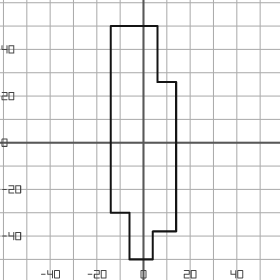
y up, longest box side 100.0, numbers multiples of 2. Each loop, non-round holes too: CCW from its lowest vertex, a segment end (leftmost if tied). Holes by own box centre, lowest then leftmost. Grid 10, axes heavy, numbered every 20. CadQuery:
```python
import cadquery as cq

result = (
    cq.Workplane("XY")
    .moveTo(-6.0, -50.0)
    .lineTo(4.0, -50.0)
    .lineTo(4.0, -38.0)
    .lineTo(14.0, -38.0)
    .lineTo(14.0, 26.0)
    .lineTo(6.0, 26.0)
    .lineTo(6.0, 50.0)
    .lineTo(-14.0, 50.0)
    .lineTo(-14.0, -30.0)
    .lineTo(-6.0, -30.0)
    .close()
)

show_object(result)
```